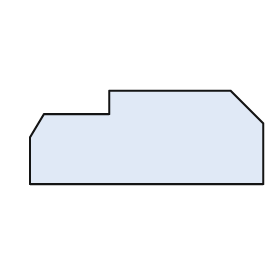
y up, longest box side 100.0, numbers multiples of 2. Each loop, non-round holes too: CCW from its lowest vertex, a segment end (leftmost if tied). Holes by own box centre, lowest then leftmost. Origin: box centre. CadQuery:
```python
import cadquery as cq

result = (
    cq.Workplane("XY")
    .moveTo(-50.0, -20.0)
    .lineTo(50.0, -20.0)
    .lineTo(50.0, 6.0)
    .lineTo(36.0, 20.0)
    .lineTo(-16.0, 20.0)
    .lineTo(-16.0, 10.0)
    .lineTo(-44.0, 10.0)
    .lineTo(-50.0, 0.0)
    .close()
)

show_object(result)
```